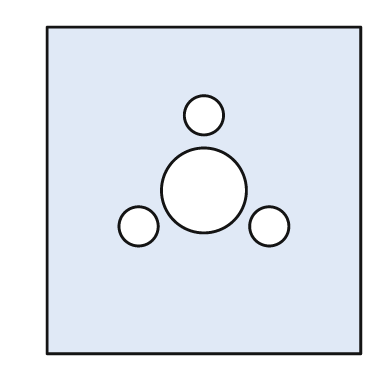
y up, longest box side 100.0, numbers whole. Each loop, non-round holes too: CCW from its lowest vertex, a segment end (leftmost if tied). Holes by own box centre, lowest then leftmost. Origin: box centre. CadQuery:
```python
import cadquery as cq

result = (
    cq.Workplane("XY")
    .moveTo(-48.0, -50.0)
    .lineTo(48.0, -50.0)
    .lineTo(48.0, 50.0)
    .lineTo(-48.0, 50.0)
    .close()
    .moveTo(-20.0, -11.0)
    .circle(6.0)
    .moveTo(20.0, -11.0)
    .circle(6.0)
    .moveTo(0.0, 0.0)
    .circle(13.0)
    .moveTo(0.0, 23.0)
    .circle(6.0)
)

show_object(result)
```